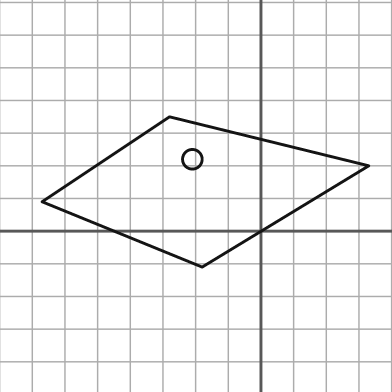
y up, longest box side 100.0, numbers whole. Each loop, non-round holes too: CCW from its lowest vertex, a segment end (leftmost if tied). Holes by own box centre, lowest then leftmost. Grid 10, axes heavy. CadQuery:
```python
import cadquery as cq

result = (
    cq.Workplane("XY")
    .moveTo(-18.0, -11.0)
    .lineTo(33.0, 20.0)
    .lineTo(-28.0, 35.0)
    .lineTo(-67.0, 9.0)
    .close()
    .moveTo(-21.0, 22.0)
    .circle(3.0)
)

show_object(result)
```